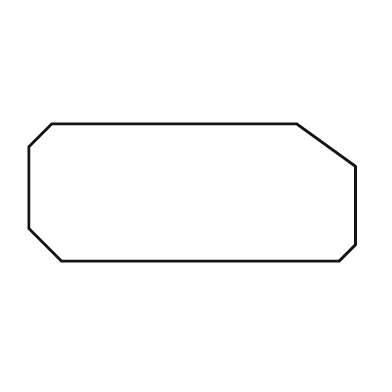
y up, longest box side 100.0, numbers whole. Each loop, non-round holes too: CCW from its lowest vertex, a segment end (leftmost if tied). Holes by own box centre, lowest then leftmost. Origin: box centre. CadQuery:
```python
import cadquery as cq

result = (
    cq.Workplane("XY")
    .moveTo(-40.0, -21.0)
    .lineTo(45.0, -21.0)
    .lineTo(50.0, -16.0)
    .lineTo(50.0, 8.0)
    .lineTo(32.0, 21.0)
    .lineTo(-43.0, 21.0)
    .lineTo(-50.0, 14.0)
    .lineTo(-50.0, -11.0)
    .close()
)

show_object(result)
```